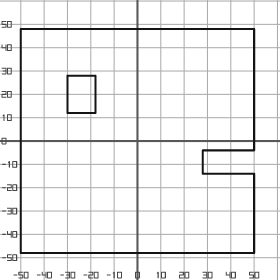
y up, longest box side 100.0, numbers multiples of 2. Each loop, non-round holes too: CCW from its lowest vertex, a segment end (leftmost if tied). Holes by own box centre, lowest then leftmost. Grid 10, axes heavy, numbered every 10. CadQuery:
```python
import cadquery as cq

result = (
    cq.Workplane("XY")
    .moveTo(-50.0, -48.0)
    .lineTo(50.0, -48.0)
    .lineTo(50.0, -14.0)
    .lineTo(28.0, -14.0)
    .lineTo(28.0, -4.0)
    .lineTo(50.0, -4.0)
    .lineTo(50.0, 48.0)
    .lineTo(-50.0, 48.0)
    .close()
    .moveTo(-30.0, 12.0)
    .lineTo(-18.0, 12.0)
    .lineTo(-18.0, 28.0)
    .lineTo(-30.0, 28.0)
    .close()
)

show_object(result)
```